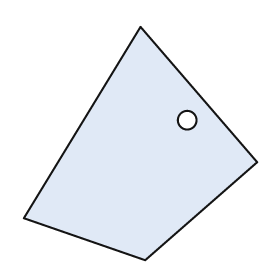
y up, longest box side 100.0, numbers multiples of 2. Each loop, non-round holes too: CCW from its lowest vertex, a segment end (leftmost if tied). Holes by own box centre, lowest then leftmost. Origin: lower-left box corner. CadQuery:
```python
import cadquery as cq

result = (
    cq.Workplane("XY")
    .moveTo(52.0, 0.0)
    .lineTo(100.0, 42.0)
    .lineTo(50.0, 100.0)
    .lineTo(0.0, 18.0)
    .close()
    .moveTo(70.0, 60.0)
    .circle(4.0)
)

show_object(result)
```